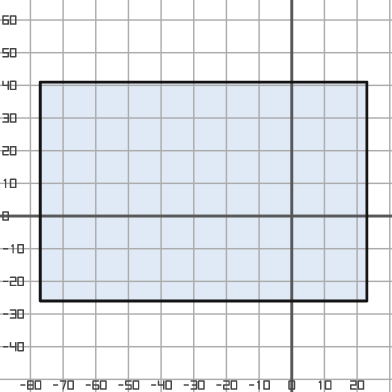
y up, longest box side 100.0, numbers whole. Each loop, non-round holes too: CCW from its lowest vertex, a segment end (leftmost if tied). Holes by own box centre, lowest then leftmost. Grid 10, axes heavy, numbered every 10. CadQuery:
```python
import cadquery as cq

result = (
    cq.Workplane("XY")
    .moveTo(-77.0, -26.0)
    .lineTo(23.0, -26.0)
    .lineTo(23.0, 41.0)
    .lineTo(-77.0, 41.0)
    .close()
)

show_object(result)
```